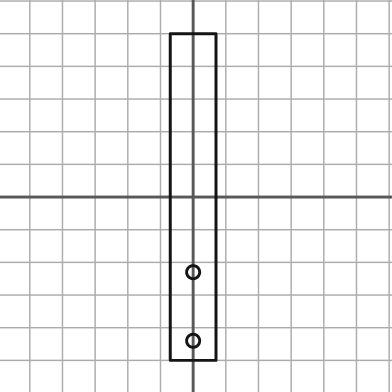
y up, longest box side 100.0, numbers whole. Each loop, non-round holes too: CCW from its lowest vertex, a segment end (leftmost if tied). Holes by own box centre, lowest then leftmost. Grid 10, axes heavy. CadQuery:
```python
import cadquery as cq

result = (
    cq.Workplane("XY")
    .moveTo(-7.0, -50.0)
    .lineTo(7.0, -50.0)
    .lineTo(7.0, 50.0)
    .lineTo(-7.0, 50.0)
    .close()
    .moveTo(0.0, -44.0)
    .circle(2.0)
    .moveTo(0.0, -23.0)
    .circle(2.0)
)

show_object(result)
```